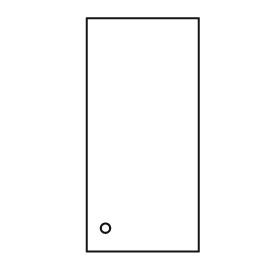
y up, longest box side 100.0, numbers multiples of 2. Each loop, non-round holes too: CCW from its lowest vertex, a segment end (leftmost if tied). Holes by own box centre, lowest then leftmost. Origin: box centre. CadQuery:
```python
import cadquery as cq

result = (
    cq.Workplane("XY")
    .moveTo(-24.0, -50.0)
    .lineTo(24.0, -50.0)
    .lineTo(24.0, 50.0)
    .lineTo(-24.0, 50.0)
    .close()
    .moveTo(-16.0, -40.0)
    .circle(2.0)
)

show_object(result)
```